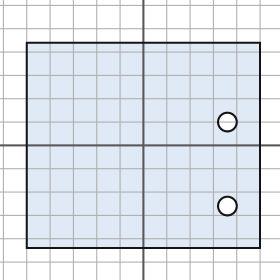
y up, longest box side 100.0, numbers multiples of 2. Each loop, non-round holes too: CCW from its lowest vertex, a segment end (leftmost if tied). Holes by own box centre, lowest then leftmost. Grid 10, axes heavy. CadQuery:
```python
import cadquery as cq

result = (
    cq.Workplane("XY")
    .moveTo(-50.0, -44.0)
    .lineTo(50.0, -44.0)
    .lineTo(50.0, 44.0)
    .lineTo(-50.0, 44.0)
    .close()
    .moveTo(36.0, -26.0)
    .circle(4.0)
    .moveTo(36.0, 10.0)
    .circle(4.0)
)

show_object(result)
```